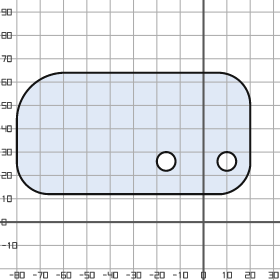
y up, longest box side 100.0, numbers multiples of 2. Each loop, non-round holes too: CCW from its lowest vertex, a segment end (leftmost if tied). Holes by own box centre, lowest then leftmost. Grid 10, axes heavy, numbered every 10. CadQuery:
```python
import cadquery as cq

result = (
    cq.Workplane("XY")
    .moveTo(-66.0, 12.0)
    .lineTo(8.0, 12.0)
    .threePointArc((16.0, 16.0), (20.0, 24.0))
    .lineTo(20.0, 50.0)
    .threePointArc((16.0, 60.0), (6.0, 64.0))
    .lineTo(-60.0, 64.0)
    .threePointArc((-74.0, 58.0), (-80.0, 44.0))
    .lineTo(-80.0, 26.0)
    .threePointArc((-76.0, 16.0), (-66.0, 12.0))
    .close()
    .moveTo(-16.0, 26.0)
    .circle(4.0)
    .moveTo(10.0, 26.0)
    .circle(4.0)
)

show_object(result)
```